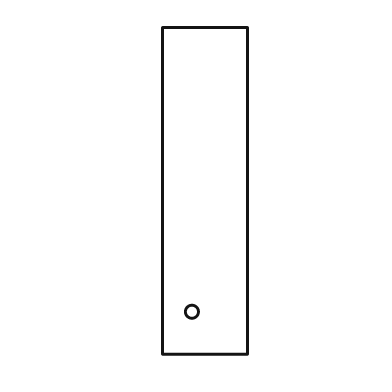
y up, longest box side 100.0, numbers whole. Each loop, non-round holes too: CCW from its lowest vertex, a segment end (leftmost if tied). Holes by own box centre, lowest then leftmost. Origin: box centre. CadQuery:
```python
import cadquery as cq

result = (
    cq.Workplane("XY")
    .moveTo(-13.0, -50.0)
    .lineTo(13.0, -50.0)
    .lineTo(13.0, 50.0)
    .lineTo(-13.0, 50.0)
    .close()
    .moveTo(-4.0, -37.0)
    .circle(2.0)
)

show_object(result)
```